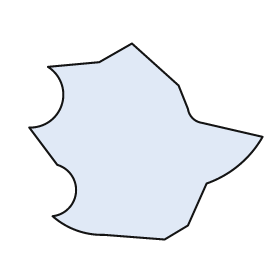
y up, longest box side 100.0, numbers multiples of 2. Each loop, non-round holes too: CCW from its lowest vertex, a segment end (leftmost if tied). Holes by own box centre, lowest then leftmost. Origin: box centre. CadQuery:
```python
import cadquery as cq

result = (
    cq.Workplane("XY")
    .moveTo(8.0, -42.0)
    .lineTo(18.0, -36.0)
    .lineTo(26.0, -18.0)
    .threePointArc((40.0, -10.0), (50.0, 2.0))
    .lineTo(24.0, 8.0)
    .threePointArc((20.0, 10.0), (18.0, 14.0))
    .lineTo(14.0, 24.0)
    .lineTo(-6.0, 42.0)
    .lineTo(-20.0, 34.0)
    .lineTo(-42.0, 32.0)
    .threePointArc((-36.0, 16.0), (-50.0, 6.0))
    .lineTo(-38.0, -10.0)
    .threePointArc((-30.0, -22.0), (-40.0, -32.0))
    .threePointArc((-30.0, -38.0), (-18.0, -40.0))
    .close()
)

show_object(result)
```